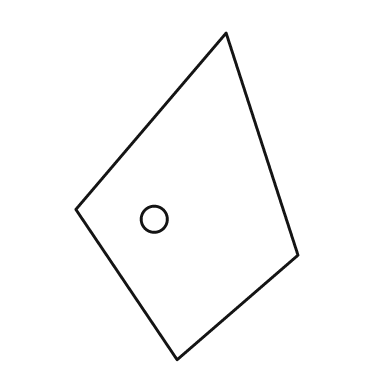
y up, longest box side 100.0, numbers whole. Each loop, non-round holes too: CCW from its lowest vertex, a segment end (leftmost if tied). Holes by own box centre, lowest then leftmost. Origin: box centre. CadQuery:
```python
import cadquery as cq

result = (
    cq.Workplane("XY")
    .moveTo(-3.0, -50.0)
    .lineTo(34.0, -18.0)
    .lineTo(12.0, 50.0)
    .lineTo(-34.0, -4.0)
    .close()
    .moveTo(-10.0, -7.0)
    .circle(4.0)
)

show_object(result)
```